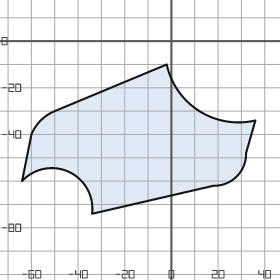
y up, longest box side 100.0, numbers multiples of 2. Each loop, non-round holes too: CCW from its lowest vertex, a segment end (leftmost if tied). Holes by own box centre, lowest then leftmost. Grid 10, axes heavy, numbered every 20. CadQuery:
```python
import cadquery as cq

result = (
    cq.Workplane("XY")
    .moveTo(-34.0, -74.0)
    .lineTo(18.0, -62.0)
    .threePointArc((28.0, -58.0), (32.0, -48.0))
    .lineTo(36.0, -34.0)
    .threePointArc((12.0, -30.0), (-2.0, -10.0))
    .lineTo(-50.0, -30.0)
    .threePointArc((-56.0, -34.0), (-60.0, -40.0))
    .lineTo(-64.0, -60.0)
    .threePointArc((-44.0, -56.0), (-34.0, -74.0))
    .close()
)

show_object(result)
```